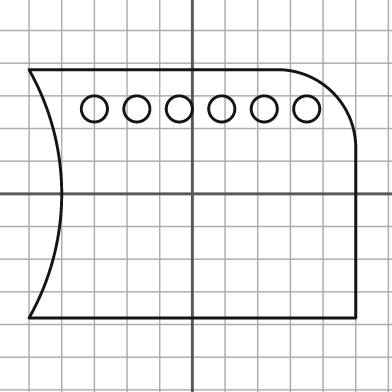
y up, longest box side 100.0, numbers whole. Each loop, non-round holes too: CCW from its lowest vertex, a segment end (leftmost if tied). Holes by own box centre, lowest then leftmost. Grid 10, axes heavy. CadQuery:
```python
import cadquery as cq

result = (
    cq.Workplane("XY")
    .moveTo(-50.0, -38.0)
    .lineTo(50.0, -38.0)
    .lineTo(50.0, 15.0)
    .threePointArc((43.0, 31.0), (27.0, 38.0))
    .lineTo(-50.0, 38.0)
    .threePointArc((-40.0, 0.0), (-50.0, -38.0))
    .close()
    .moveTo(-30.0, 26.0)
    .circle(4.0)
    .moveTo(-17.0, 26.0)
    .circle(4.0)
    .moveTo(-4.0, 26.0)
    .circle(4.0)
    .moveTo(9.0, 26.0)
    .circle(4.0)
    .moveTo(22.0, 26.0)
    .circle(4.0)
    .moveTo(35.0, 26.0)
    .circle(4.0)
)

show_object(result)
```